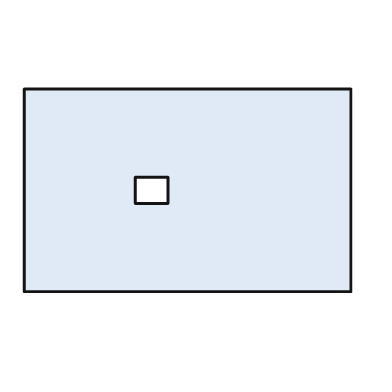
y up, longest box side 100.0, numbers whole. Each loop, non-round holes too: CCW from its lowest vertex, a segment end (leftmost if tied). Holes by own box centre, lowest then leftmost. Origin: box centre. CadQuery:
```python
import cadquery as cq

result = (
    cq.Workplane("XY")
    .moveTo(-50.0, -31.0)
    .lineTo(50.0, -31.0)
    .lineTo(50.0, 31.0)
    .lineTo(-50.0, 31.0)
    .close()
    .moveTo(-16.0, -4.0)
    .lineTo(-6.0, -4.0)
    .lineTo(-6.0, 4.0)
    .lineTo(-16.0, 4.0)
    .close()
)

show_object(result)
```